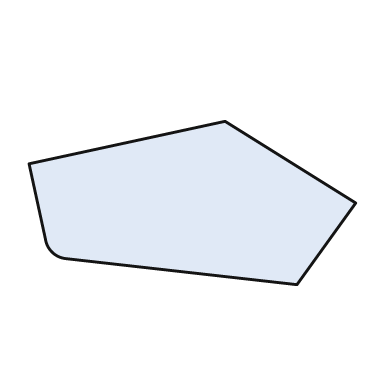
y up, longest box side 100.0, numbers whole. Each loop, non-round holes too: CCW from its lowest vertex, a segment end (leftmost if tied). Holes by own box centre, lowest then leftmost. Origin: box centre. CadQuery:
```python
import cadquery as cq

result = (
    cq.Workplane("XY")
    .moveTo(32.0, -25.0)
    .lineTo(50.0, 0.0)
    .lineTo(10.0, 25.0)
    .lineTo(-50.0, 12.0)
    .lineTo(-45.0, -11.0)
    .threePointArc((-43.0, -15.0), (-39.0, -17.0))
    .close()
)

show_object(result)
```